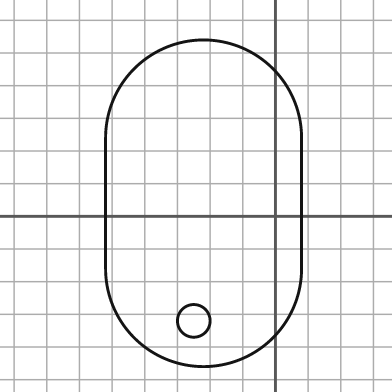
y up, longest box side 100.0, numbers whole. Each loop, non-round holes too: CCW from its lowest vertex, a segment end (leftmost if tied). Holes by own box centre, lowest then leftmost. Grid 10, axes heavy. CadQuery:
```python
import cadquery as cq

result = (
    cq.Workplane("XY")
    .moveTo(-52.0, -16.0)
    .threePointArc((-22.0, -46.0), (8.0, -16.0))
    .lineTo(8.0, 24.0)
    .threePointArc((-22.0, 54.0), (-52.0, 24.0))
    .close()
    .moveTo(-25.0, -32.0)
    .circle(5.0)
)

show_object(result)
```